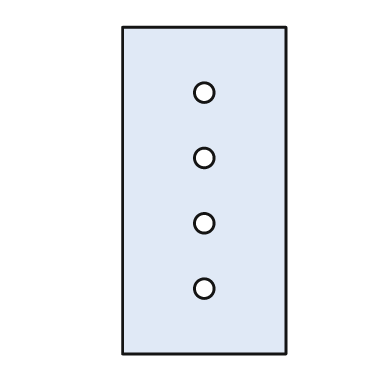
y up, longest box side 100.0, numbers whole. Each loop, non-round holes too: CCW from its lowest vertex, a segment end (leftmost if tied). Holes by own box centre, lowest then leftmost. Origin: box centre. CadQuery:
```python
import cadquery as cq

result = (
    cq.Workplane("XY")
    .moveTo(-25.0, -50.0)
    .lineTo(25.0, -50.0)
    .lineTo(25.0, 50.0)
    .lineTo(-25.0, 50.0)
    .close()
    .moveTo(0.0, -30.0)
    .circle(3.0)
    .moveTo(0.0, -10.0)
    .circle(3.0)
    .moveTo(0.0, 10.0)
    .circle(3.0)
    .moveTo(0.0, 30.0)
    .circle(3.0)
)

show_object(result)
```